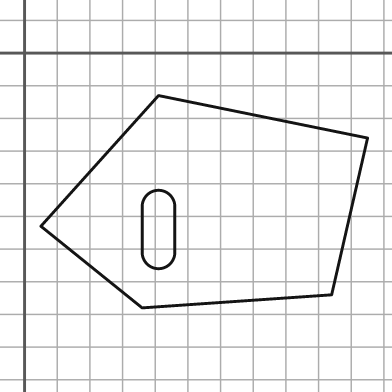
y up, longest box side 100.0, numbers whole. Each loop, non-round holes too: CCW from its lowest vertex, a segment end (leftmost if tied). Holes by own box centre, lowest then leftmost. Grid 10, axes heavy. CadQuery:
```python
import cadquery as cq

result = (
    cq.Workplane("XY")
    .moveTo(36.0, -78.0)
    .lineTo(94.0, -74.0)
    .lineTo(105.0, -26.0)
    .lineTo(41.0, -13.0)
    .lineTo(5.0, -53.0)
    .close()
    .moveTo(36.0, -61.0)
    .threePointArc((41.0, -66.0), (46.0, -61.0))
    .lineTo(46.0, -47.0)
    .threePointArc((41.0, -42.0), (36.0, -47.0))
    .close()
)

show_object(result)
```